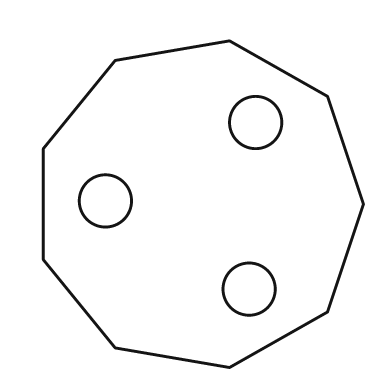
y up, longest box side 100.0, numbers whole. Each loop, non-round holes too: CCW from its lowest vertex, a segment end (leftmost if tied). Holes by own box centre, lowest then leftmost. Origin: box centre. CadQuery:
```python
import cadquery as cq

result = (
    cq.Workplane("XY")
    .moveTo(8.0, -50.0)
    .lineTo(38.0, -33.0)
    .lineTo(49.0, 0.0)
    .lineTo(38.0, 33.0)
    .lineTo(8.0, 50.0)
    .lineTo(-27.0, 44.0)
    .lineTo(-49.0, 17.0)
    .lineTo(-49.0, -17.0)
    .lineTo(-27.0, -44.0)
    .close()
    .moveTo(14.0, -26.0)
    .circle(8.0)
    .moveTo(-30.0, 1.0)
    .circle(8.0)
    .moveTo(16.0, 25.0)
    .circle(8.0)
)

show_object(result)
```